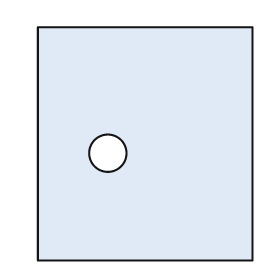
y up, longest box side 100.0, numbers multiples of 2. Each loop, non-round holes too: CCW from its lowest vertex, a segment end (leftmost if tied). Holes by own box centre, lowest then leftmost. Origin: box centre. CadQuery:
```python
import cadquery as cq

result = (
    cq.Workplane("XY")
    .moveTo(-46.0, -50.0)
    .lineTo(46.0, -50.0)
    .lineTo(46.0, 50.0)
    .lineTo(-46.0, 50.0)
    .close()
    .moveTo(-16.0, -4.0)
    .circle(8.0)
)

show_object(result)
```